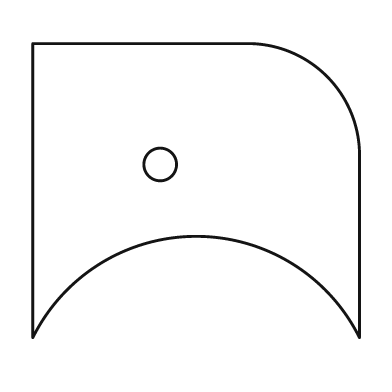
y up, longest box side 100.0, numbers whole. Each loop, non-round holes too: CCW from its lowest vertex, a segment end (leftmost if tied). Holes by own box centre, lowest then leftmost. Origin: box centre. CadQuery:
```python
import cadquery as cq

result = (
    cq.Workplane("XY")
    .moveTo(-50.0, -45.0)
    .threePointArc((0.0, -14.0), (50.0, -45.0))
    .lineTo(50.0, 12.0)
    .threePointArc((40.0, 35.0), (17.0, 45.0))
    .lineTo(-50.0, 45.0)
    .close()
    .moveTo(-11.0, 8.0)
    .circle(5.0)
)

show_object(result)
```